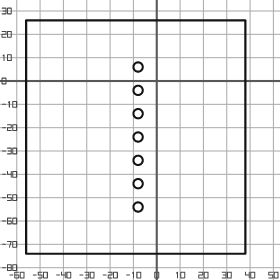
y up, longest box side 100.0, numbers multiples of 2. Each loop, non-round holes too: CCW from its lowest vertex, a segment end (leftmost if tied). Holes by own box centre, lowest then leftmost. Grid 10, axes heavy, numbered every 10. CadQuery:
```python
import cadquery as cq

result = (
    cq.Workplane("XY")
    .moveTo(-56.0, -74.0)
    .lineTo(38.0, -74.0)
    .lineTo(38.0, 26.0)
    .lineTo(-56.0, 26.0)
    .close()
    .moveTo(-8.0, -54.0)
    .circle(2.0)
    .moveTo(-8.0, -44.0)
    .circle(2.0)
    .moveTo(-8.0, -34.0)
    .circle(2.0)
    .moveTo(-8.0, -24.0)
    .circle(2.0)
    .moveTo(-8.0, -14.0)
    .circle(2.0)
    .moveTo(-8.0, -4.0)
    .circle(2.0)
    .moveTo(-8.0, 6.0)
    .circle(2.0)
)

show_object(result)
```